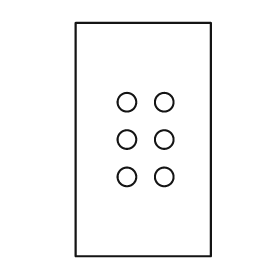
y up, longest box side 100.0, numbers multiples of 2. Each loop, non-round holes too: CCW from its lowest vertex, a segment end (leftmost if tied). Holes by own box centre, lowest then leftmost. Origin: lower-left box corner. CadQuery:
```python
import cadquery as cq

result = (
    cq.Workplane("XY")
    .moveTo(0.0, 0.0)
    .lineTo(58.0, 0.0)
    .lineTo(58.0, 100.0)
    .lineTo(0.0, 100.0)
    .close()
    .moveTo(22.0, 34.0)
    .circle(4.0)
    .moveTo(38.0, 34.0)
    .circle(4.0)
    .moveTo(22.0, 50.0)
    .circle(4.0)
    .moveTo(38.0, 50.0)
    .circle(4.0)
    .moveTo(22.0, 66.0)
    .circle(4.0)
    .moveTo(38.0, 66.0)
    .circle(4.0)
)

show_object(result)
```